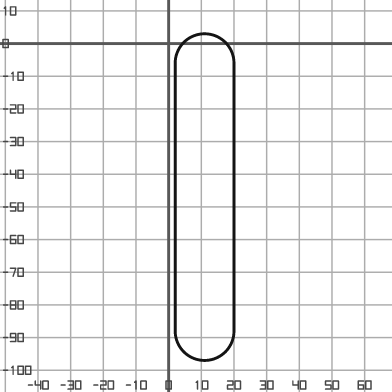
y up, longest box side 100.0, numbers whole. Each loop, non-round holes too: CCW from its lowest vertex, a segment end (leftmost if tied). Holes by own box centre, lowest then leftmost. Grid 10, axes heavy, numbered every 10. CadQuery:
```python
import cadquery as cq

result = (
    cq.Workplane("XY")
    .moveTo(2.0, -88.0)
    .threePointArc((11.0, -97.0), (20.0, -88.0))
    .lineTo(20.0, -6.0)
    .threePointArc((11.0, 3.0), (2.0, -6.0))
    .close()
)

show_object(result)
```